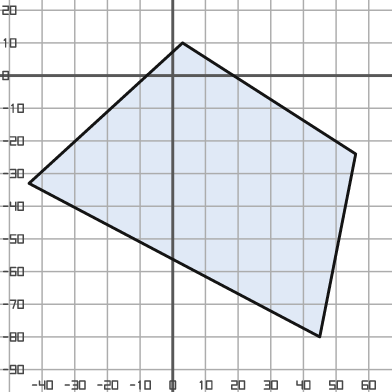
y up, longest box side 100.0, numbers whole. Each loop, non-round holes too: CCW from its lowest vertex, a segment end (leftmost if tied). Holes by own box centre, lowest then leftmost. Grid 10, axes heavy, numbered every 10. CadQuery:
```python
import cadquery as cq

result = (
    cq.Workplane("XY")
    .moveTo(45.0, -80.0)
    .lineTo(56.0, -24.0)
    .lineTo(3.0, 10.0)
    .lineTo(-44.0, -33.0)
    .close()
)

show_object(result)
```